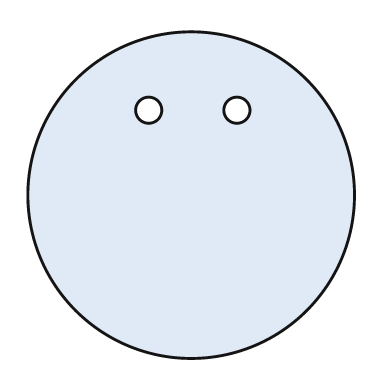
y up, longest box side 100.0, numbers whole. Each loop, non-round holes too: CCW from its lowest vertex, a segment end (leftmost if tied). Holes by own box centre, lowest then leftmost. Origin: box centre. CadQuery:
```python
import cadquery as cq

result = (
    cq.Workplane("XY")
    .moveTo(0.0, 0.0)
    .circle(50.0)
    .moveTo(-13.0, 26.0)
    .circle(4.0)
    .moveTo(14.0, 26.0)
    .circle(4.0)
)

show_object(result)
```